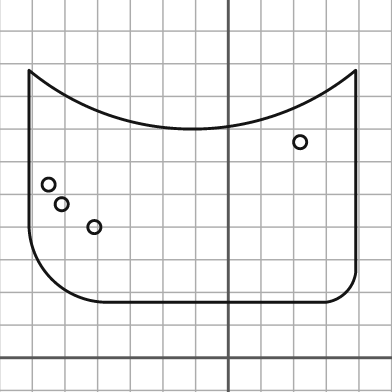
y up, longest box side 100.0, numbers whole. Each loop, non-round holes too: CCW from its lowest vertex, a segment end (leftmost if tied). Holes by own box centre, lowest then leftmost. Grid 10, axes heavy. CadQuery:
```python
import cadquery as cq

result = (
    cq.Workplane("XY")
    .moveTo(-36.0, 17.0)
    .lineTo(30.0, 17.0)
    .threePointArc((36.0, 20.0), (39.0, 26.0))
    .lineTo(39.0, 88.0)
    .threePointArc((-11.0, 70.0), (-61.0, 88.0))
    .lineTo(-61.0, 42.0)
    .threePointArc((-54.0, 24.0), (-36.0, 17.0))
    .close()
    .moveTo(-41.0, 40.0)
    .circle(2.0)
    .moveTo(-51.0, 47.0)
    .circle(2.0)
    .moveTo(-55.0, 53.0)
    .circle(2.0)
    .moveTo(22.0, 66.0)
    .circle(2.0)
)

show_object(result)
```